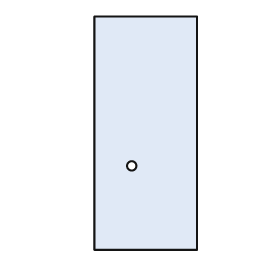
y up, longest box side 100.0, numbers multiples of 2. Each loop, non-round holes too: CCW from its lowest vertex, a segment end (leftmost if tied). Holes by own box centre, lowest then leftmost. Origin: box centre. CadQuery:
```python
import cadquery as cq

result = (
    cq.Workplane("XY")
    .moveTo(-22.0, -50.0)
    .lineTo(22.0, -50.0)
    .lineTo(22.0, 50.0)
    .lineTo(-22.0, 50.0)
    .close()
    .moveTo(-6.0, -14.0)
    .circle(2.0)
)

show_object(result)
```